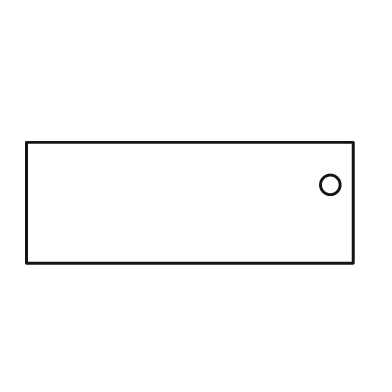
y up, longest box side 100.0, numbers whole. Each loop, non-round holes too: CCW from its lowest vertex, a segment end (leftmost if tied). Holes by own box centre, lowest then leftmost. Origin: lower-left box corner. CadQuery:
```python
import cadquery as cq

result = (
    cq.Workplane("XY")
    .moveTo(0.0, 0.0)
    .lineTo(100.0, 0.0)
    .lineTo(100.0, 37.0)
    .lineTo(0.0, 37.0)
    .close()
    .moveTo(93.0, 24.0)
    .circle(3.0)
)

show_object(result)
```